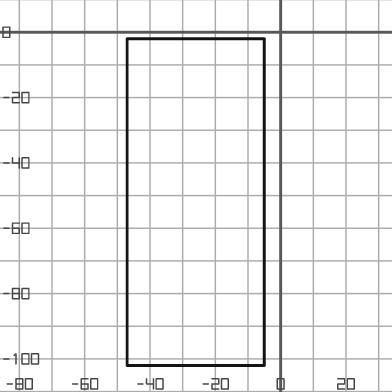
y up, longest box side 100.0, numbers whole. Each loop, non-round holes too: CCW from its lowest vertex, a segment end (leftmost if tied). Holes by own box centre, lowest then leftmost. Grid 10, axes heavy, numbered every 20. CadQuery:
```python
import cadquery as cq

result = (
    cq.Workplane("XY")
    .moveTo(-47.0, -102.0)
    .lineTo(-5.0, -102.0)
    .lineTo(-5.0, -2.0)
    .lineTo(-47.0, -2.0)
    .close()
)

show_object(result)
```